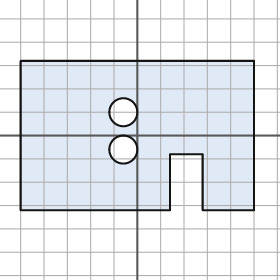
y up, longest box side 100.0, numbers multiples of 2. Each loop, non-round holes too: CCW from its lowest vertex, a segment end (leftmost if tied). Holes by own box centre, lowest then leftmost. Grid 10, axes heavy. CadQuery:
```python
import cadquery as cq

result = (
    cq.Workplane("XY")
    .moveTo(-50.0, -32.0)
    .lineTo(14.0, -32.0)
    .lineTo(14.0, -8.0)
    .lineTo(28.0, -8.0)
    .lineTo(28.0, -32.0)
    .lineTo(50.0, -32.0)
    .lineTo(50.0, 32.0)
    .lineTo(-50.0, 32.0)
    .close()
    .moveTo(-6.0, -6.0)
    .circle(6.0)
    .moveTo(-6.0, 10.0)
    .circle(6.0)
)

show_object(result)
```